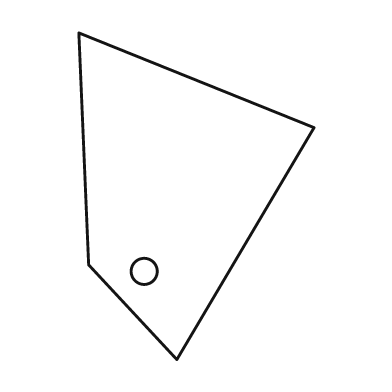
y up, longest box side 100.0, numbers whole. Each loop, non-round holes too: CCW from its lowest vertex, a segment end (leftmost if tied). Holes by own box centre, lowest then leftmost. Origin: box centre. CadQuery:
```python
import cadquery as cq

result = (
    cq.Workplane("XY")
    .moveTo(-6.0, -50.0)
    .lineTo(36.0, 21.0)
    .lineTo(-36.0, 50.0)
    .lineTo(-33.0, -21.0)
    .close()
    .moveTo(-16.0, -23.0)
    .circle(4.0)
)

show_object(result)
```